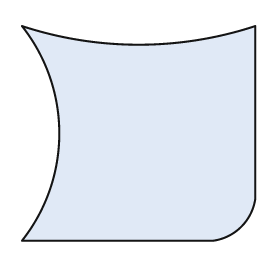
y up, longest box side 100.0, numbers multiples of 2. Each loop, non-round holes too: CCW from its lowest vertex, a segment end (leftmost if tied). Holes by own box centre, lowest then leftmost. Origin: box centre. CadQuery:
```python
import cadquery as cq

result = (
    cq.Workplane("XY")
    .moveTo(-50.0, -46.0)
    .lineTo(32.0, -46.0)
    .threePointArc((44.0, -40.0), (50.0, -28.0))
    .lineTo(50.0, 46.0)
    .threePointArc((0.0, 38.0), (-50.0, 46.0))
    .threePointArc((-34.0, 0.0), (-50.0, -46.0))
    .close()
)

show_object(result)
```